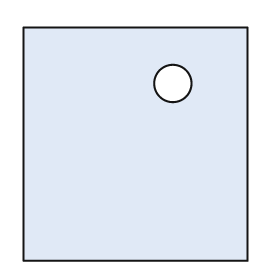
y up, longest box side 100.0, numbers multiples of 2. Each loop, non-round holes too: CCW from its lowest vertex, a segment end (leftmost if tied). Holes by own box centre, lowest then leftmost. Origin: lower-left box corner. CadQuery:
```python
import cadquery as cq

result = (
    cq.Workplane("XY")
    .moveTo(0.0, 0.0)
    .lineTo(96.0, 0.0)
    .lineTo(96.0, 100.0)
    .lineTo(0.0, 100.0)
    .close()
    .moveTo(64.0, 76.0)
    .circle(8.0)
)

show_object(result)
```